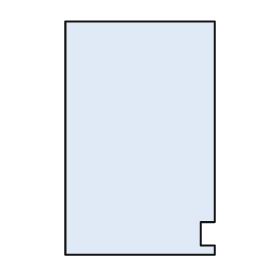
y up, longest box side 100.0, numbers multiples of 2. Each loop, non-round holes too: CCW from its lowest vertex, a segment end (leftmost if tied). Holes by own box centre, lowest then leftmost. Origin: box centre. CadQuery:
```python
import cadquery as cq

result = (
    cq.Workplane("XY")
    .moveTo(-32.0, -50.0)
    .lineTo(32.0, -50.0)
    .lineTo(32.0, -46.0)
    .lineTo(26.0, -46.0)
    .lineTo(26.0, -36.0)
    .lineTo(32.0, -36.0)
    .lineTo(32.0, 50.0)
    .lineTo(-32.0, 50.0)
    .close()
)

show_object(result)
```